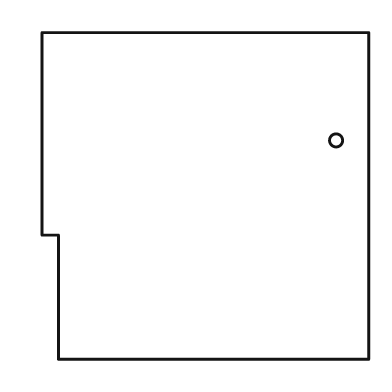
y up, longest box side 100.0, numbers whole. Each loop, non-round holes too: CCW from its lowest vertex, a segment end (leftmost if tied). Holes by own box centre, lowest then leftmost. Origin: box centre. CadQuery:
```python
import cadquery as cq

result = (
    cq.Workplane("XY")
    .moveTo(-45.0, -50.0)
    .lineTo(50.0, -50.0)
    .lineTo(50.0, 50.0)
    .lineTo(-50.0, 50.0)
    .lineTo(-50.0, -12.0)
    .lineTo(-45.0, -12.0)
    .close()
    .moveTo(40.0, 17.0)
    .circle(2.0)
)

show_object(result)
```